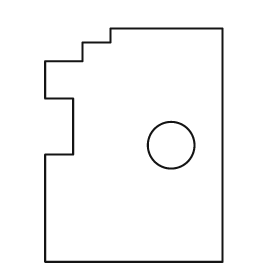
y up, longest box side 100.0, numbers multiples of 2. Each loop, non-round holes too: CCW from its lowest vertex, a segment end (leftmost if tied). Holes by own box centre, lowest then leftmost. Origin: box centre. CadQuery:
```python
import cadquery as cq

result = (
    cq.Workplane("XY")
    .moveTo(-38.0, -50.0)
    .lineTo(38.0, -50.0)
    .lineTo(38.0, 50.0)
    .lineTo(-10.0, 50.0)
    .lineTo(-10.0, 44.0)
    .lineTo(-22.0, 44.0)
    .lineTo(-22.0, 36.0)
    .lineTo(-38.0, 36.0)
    .lineTo(-38.0, 20.0)
    .lineTo(-26.0, 20.0)
    .lineTo(-26.0, -4.0)
    .lineTo(-38.0, -4.0)
    .close()
    .moveTo(16.0, 0.0)
    .circle(10.0)
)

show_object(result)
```